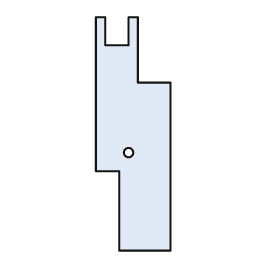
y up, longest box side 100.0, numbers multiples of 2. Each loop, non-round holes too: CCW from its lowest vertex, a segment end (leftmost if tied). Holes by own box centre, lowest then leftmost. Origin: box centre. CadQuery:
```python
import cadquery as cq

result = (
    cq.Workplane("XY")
    .moveTo(-6.0, -50.0)
    .lineTo(16.0, -50.0)
    .lineTo(16.0, 22.0)
    .lineTo(2.0, 22.0)
    .lineTo(2.0, 50.0)
    .lineTo(-2.0, 50.0)
    .lineTo(-2.0, 38.0)
    .lineTo(-12.0, 38.0)
    .lineTo(-12.0, 50.0)
    .lineTo(-16.0, 50.0)
    .lineTo(-16.0, -16.0)
    .lineTo(-6.0, -16.0)
    .close()
    .moveTo(-2.0, -8.0)
    .circle(2.0)
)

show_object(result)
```